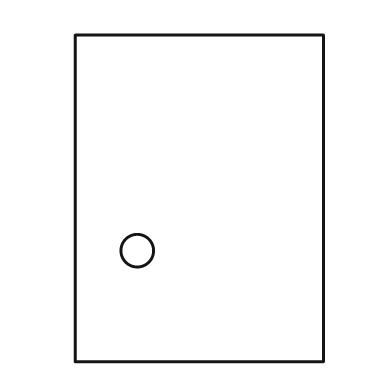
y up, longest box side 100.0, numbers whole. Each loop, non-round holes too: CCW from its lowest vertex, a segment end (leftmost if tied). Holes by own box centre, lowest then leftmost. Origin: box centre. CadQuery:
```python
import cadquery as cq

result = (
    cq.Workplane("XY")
    .moveTo(-38.0, -50.0)
    .lineTo(38.0, -50.0)
    .lineTo(38.0, 50.0)
    .lineTo(-38.0, 50.0)
    .close()
    .moveTo(-19.0, -16.0)
    .circle(5.0)
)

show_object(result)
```